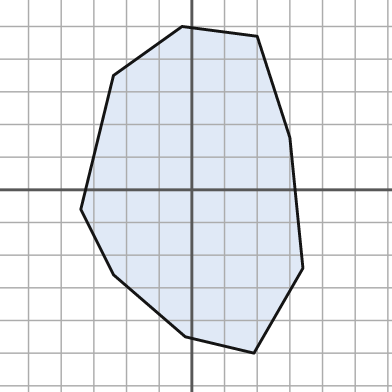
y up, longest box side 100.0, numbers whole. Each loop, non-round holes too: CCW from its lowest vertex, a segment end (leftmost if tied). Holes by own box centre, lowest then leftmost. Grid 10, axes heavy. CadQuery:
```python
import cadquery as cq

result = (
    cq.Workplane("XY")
    .moveTo(19.0, -50.0)
    .lineTo(34.0, -24.0)
    .lineTo(30.0, 16.0)
    .lineTo(20.0, 47.0)
    .lineTo(-3.0, 50.0)
    .lineTo(-24.0, 35.0)
    .lineTo(-34.0, -6.0)
    .lineTo(-24.0, -26.0)
    .lineTo(-2.0, -45.0)
    .close()
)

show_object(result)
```